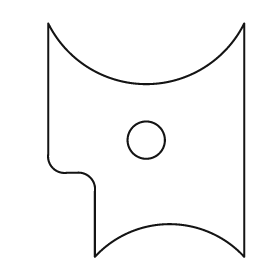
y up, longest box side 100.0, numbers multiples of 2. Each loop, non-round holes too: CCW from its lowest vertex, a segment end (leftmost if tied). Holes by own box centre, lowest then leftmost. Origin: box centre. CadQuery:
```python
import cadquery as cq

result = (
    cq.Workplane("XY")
    .moveTo(-22.0, -50.0)
    .threePointArc((10.0, -36.0), (42.0, -50.0))
    .lineTo(42.0, 50.0)
    .threePointArc((0.0, 24.0), (-42.0, 50.0))
    .lineTo(-42.0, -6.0)
    .threePointArc((-40.0, -12.0), (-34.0, -14.0))
    .lineTo(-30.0, -14.0)
    .threePointArc((-24.0, -16.0), (-22.0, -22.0))
    .close()
    .moveTo(0.0, 0.0)
    .circle(8.0)
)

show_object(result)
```